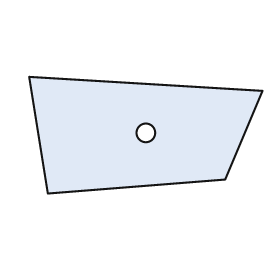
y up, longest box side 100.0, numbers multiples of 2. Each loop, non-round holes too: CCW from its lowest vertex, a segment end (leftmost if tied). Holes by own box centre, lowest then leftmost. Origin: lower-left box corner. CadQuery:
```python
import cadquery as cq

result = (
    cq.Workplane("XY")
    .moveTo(8.0, 0.0)
    .lineTo(84.0, 6.0)
    .lineTo(100.0, 44.0)
    .lineTo(0.0, 50.0)
    .close()
    .moveTo(50.0, 26.0)
    .circle(4.0)
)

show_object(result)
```